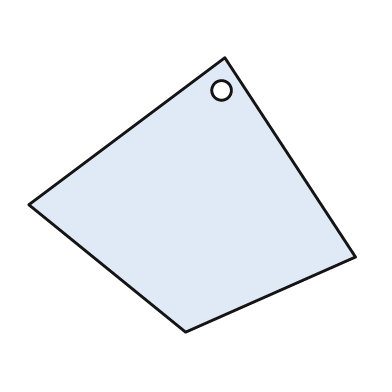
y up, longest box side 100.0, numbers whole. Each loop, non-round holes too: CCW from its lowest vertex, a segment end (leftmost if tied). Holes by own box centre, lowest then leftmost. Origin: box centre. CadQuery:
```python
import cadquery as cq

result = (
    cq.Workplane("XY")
    .moveTo(-2.0, -42.0)
    .lineTo(50.0, -19.0)
    .lineTo(10.0, 42.0)
    .lineTo(-50.0, -3.0)
    .close()
    .moveTo(9.0, 32.0)
    .circle(3.0)
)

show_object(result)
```